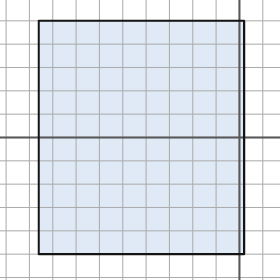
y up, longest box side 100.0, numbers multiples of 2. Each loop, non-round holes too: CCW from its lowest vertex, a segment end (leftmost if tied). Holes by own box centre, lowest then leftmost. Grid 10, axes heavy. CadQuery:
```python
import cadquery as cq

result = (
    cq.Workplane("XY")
    .moveTo(-86.0, -50.0)
    .lineTo(2.0, -50.0)
    .lineTo(2.0, 50.0)
    .lineTo(-86.0, 50.0)
    .close()
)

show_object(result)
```